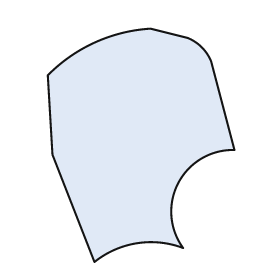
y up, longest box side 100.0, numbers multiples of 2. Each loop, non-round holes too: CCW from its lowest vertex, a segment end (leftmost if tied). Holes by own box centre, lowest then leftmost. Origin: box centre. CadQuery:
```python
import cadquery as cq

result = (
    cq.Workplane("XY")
    .moveTo(-20.0, -50.0)
    .threePointArc((-2.0, -42.0), (18.0, -44.0))
    .threePointArc((16.0, -16.0), (40.0, -2.0))
    .lineTo(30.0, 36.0)
    .threePointArc((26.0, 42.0), (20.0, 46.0))
    .lineTo(4.0, 50.0)
    .threePointArc((-20.0, 44.0), (-40.0, 30.0))
    .lineTo(-38.0, -4.0)
    .close()
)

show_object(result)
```